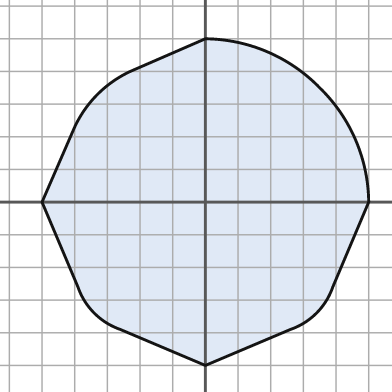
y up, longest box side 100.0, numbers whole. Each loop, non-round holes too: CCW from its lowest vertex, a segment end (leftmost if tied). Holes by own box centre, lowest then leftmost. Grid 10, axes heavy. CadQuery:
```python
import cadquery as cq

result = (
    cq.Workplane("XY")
    .moveTo(0.0, -50.0)
    .lineTo(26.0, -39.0)
    .threePointArc((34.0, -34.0), (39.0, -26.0))
    .lineTo(50.0, 0.0)
    .threePointArc((46.0, 19.0), (35.0, 35.0))
    .threePointArc((19.0, 46.0), (0.0, 50.0))
    .lineTo(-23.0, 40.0)
    .threePointArc((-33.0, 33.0), (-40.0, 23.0))
    .lineTo(-50.0, 0.0)
    .lineTo(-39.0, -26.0)
    .threePointArc((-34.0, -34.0), (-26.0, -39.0))
    .close()
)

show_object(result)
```